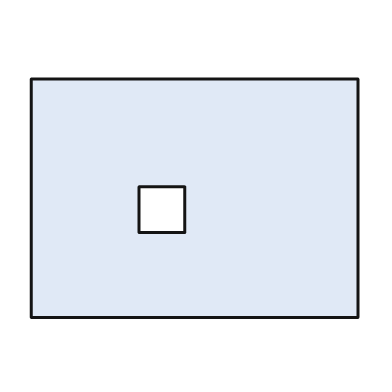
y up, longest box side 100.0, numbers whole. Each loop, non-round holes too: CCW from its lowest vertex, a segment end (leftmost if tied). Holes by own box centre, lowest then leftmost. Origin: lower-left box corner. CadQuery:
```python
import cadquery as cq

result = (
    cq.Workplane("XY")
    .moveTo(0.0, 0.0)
    .lineTo(100.0, 0.0)
    .lineTo(100.0, 73.0)
    .lineTo(0.0, 73.0)
    .close()
    .moveTo(33.0, 26.0)
    .lineTo(47.0, 26.0)
    .lineTo(47.0, 40.0)
    .lineTo(33.0, 40.0)
    .close()
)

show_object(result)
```